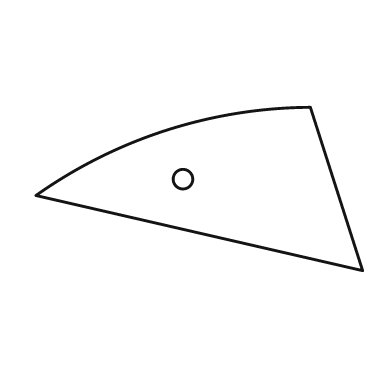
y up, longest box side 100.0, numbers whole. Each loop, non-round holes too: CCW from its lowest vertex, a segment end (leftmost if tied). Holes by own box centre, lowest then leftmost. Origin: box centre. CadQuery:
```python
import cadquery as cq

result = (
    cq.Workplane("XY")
    .moveTo(50.0, -25.0)
    .lineTo(34.0, 25.0)
    .threePointArc((-10.0, 18.0), (-50.0, -2.0))
    .close()
    .moveTo(-5.0, 3.0)
    .circle(3.0)
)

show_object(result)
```